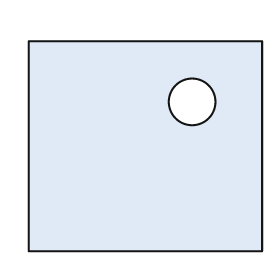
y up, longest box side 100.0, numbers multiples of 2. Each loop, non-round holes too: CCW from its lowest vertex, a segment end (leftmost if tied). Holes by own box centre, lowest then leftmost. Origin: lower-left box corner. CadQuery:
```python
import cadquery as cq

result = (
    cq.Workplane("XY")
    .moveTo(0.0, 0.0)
    .lineTo(100.0, 0.0)
    .lineTo(100.0, 90.0)
    .lineTo(0.0, 90.0)
    .close()
    .moveTo(70.0, 64.0)
    .circle(10.0)
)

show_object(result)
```